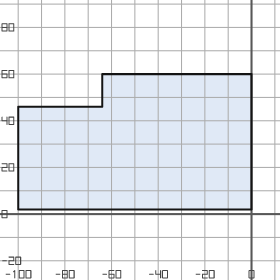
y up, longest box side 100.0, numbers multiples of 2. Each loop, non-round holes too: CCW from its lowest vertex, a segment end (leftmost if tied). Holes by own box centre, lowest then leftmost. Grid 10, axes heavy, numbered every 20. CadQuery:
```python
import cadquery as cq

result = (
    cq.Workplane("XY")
    .moveTo(-100.0, 2.0)
    .lineTo(0.0, 2.0)
    .lineTo(0.0, 60.0)
    .lineTo(-64.0, 60.0)
    .lineTo(-64.0, 46.0)
    .lineTo(-100.0, 46.0)
    .close()
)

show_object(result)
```